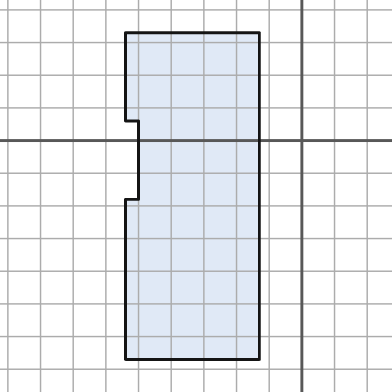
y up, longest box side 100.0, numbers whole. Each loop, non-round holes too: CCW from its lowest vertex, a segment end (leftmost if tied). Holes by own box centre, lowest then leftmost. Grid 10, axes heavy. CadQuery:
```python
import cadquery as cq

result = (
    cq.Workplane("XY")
    .moveTo(-54.0, -67.0)
    .lineTo(-13.0, -67.0)
    .lineTo(-13.0, 33.0)
    .lineTo(-54.0, 33.0)
    .lineTo(-54.0, 6.0)
    .lineTo(-50.0, 6.0)
    .lineTo(-50.0, -18.0)
    .lineTo(-54.0, -18.0)
    .close()
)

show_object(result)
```